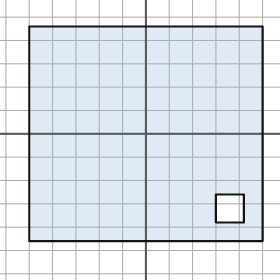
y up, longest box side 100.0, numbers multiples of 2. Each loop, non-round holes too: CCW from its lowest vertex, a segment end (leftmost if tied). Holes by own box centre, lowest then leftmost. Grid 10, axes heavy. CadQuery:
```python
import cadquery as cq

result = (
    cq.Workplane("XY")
    .moveTo(-50.0, -46.0)
    .lineTo(50.0, -46.0)
    .lineTo(50.0, 46.0)
    .lineTo(-50.0, 46.0)
    .close()
    .moveTo(30.0, -38.0)
    .lineTo(42.0, -38.0)
    .lineTo(42.0, -26.0)
    .lineTo(30.0, -26.0)
    .close()
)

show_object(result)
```